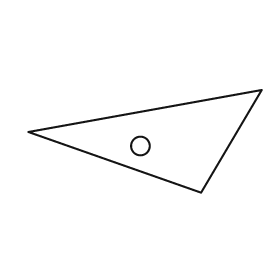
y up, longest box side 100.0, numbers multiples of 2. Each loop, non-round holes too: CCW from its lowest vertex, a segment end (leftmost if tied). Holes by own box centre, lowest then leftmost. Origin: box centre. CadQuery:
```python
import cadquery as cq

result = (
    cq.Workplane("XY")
    .moveTo(24.0, -22.0)
    .lineTo(50.0, 22.0)
    .lineTo(-50.0, 4.0)
    .close()
    .moveTo(-2.0, -2.0)
    .circle(4.0)
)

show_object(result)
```